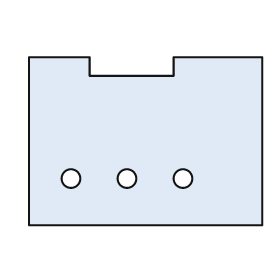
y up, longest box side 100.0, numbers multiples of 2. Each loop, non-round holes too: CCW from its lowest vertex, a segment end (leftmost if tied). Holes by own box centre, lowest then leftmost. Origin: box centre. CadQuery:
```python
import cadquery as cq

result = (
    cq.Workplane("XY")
    .moveTo(-50.0, -36.0)
    .lineTo(50.0, -36.0)
    .lineTo(50.0, 36.0)
    .lineTo(12.0, 36.0)
    .lineTo(12.0, 28.0)
    .lineTo(-24.0, 28.0)
    .lineTo(-24.0, 36.0)
    .lineTo(-50.0, 36.0)
    .close()
    .moveTo(-32.0, -16.0)
    .circle(4.0)
    .moveTo(-8.0, -16.0)
    .circle(4.0)
    .moveTo(16.0, -16.0)
    .circle(4.0)
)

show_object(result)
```